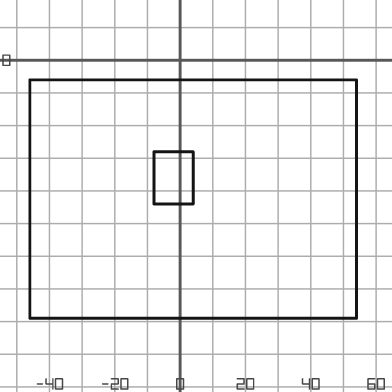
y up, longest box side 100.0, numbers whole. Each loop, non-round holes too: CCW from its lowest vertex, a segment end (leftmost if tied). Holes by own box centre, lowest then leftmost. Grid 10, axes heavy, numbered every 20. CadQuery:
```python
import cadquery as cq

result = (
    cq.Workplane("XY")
    .moveTo(-46.0, -79.0)
    .lineTo(54.0, -79.0)
    .lineTo(54.0, -6.0)
    .lineTo(-46.0, -6.0)
    .close()
    .moveTo(-8.0, -44.0)
    .lineTo(4.0, -44.0)
    .lineTo(4.0, -28.0)
    .lineTo(-8.0, -28.0)
    .close()
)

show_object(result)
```